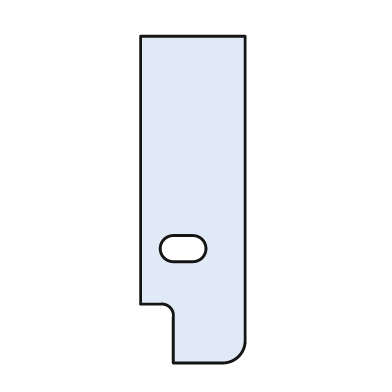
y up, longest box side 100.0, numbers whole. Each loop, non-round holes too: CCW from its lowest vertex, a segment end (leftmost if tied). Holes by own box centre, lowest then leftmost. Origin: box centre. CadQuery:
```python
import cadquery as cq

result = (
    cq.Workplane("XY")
    .moveTo(-6.0, -50.0)
    .lineTo(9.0, -50.0)
    .threePointArc((14.0, -48.0), (16.0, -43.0))
    .lineTo(16.0, 50.0)
    .lineTo(-16.0, 50.0)
    .lineTo(-16.0, -32.0)
    .lineTo(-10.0, -32.0)
    .threePointArc((-7.0, -33.0), (-6.0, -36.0))
    .close()
    .moveTo(-6.0, -19.0)
    .lineTo(0.0, -19.0)
    .threePointArc((4.0, -15.0), (0.0, -11.0))
    .lineTo(-6.0, -11.0)
    .threePointArc((-10.0, -15.0), (-6.0, -19.0))
    .close()
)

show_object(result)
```